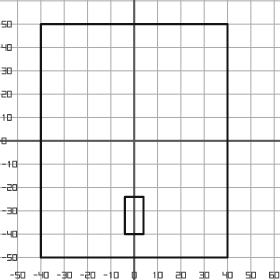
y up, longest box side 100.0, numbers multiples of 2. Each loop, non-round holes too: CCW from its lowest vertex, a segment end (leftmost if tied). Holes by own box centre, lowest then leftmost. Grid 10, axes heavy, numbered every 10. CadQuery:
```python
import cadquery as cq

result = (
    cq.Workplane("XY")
    .moveTo(-40.0, -50.0)
    .lineTo(40.0, -50.0)
    .lineTo(40.0, 50.0)
    .lineTo(-40.0, 50.0)
    .close()
    .moveTo(-4.0, -40.0)
    .lineTo(4.0, -40.0)
    .lineTo(4.0, -24.0)
    .lineTo(-4.0, -24.0)
    .close()
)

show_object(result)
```